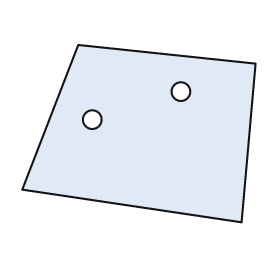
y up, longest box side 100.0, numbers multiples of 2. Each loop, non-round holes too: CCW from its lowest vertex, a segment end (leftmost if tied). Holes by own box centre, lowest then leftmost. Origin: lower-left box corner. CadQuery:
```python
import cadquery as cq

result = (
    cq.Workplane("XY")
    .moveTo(94.0, 0.0)
    .lineTo(100.0, 68.0)
    .lineTo(24.0, 76.0)
    .lineTo(0.0, 14.0)
    .close()
    .moveTo(30.0, 44.0)
    .circle(4.0)
    .moveTo(68.0, 56.0)
    .circle(4.0)
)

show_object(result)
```